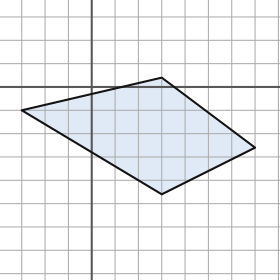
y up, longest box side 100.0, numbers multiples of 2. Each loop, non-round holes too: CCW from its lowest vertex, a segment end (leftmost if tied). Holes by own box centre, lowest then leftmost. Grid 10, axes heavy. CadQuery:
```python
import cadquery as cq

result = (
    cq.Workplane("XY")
    .moveTo(30.0, -46.0)
    .lineTo(70.0, -26.0)
    .lineTo(30.0, 4.0)
    .lineTo(-30.0, -10.0)
    .close()
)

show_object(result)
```